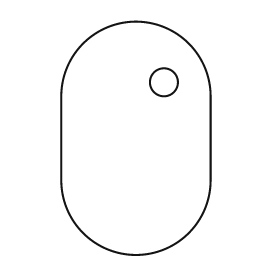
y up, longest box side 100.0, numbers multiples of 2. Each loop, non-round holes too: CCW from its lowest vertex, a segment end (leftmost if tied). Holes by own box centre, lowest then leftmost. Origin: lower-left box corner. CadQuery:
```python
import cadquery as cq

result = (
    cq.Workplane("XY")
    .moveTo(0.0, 32.0)
    .threePointArc((32.0, 0.0), (64.0, 32.0))
    .lineTo(64.0, 68.0)
    .threePointArc((32.0, 100.0), (0.0, 68.0))
    .close()
    .moveTo(44.0, 74.0)
    .circle(6.0)
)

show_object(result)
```